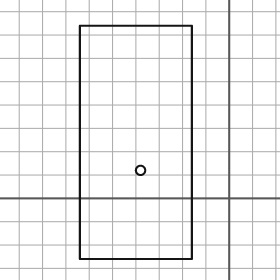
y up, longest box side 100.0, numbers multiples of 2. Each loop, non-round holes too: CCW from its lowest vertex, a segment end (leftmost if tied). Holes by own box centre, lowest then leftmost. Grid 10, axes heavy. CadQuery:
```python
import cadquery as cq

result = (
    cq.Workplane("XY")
    .moveTo(-64.0, -26.0)
    .lineTo(-16.0, -26.0)
    .lineTo(-16.0, 74.0)
    .lineTo(-64.0, 74.0)
    .close()
    .moveTo(-38.0, 12.0)
    .circle(2.0)
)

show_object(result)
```